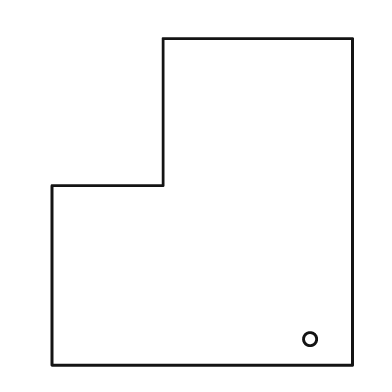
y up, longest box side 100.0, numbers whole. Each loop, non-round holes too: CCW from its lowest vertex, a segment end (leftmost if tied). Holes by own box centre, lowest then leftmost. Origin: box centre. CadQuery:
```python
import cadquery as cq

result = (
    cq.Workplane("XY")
    .moveTo(-46.0, -50.0)
    .lineTo(46.0, -50.0)
    .lineTo(46.0, 50.0)
    .lineTo(-12.0, 50.0)
    .lineTo(-12.0, 5.0)
    .lineTo(-46.0, 5.0)
    .close()
    .moveTo(33.0, -42.0)
    .circle(2.0)
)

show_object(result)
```